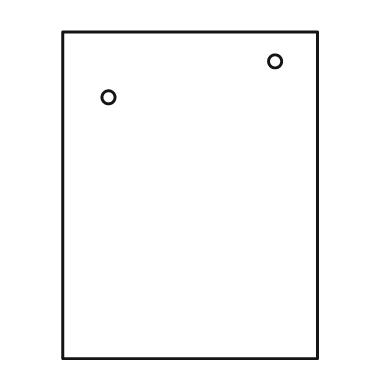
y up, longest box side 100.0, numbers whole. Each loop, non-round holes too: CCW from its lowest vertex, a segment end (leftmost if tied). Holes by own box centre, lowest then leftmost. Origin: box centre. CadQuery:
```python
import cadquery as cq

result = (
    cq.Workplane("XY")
    .moveTo(-39.0, -50.0)
    .lineTo(39.0, -50.0)
    .lineTo(39.0, 50.0)
    .lineTo(-39.0, 50.0)
    .close()
    .moveTo(-25.0, 30.0)
    .circle(2.0)
    .moveTo(26.0, 41.0)
    .circle(2.0)
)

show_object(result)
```